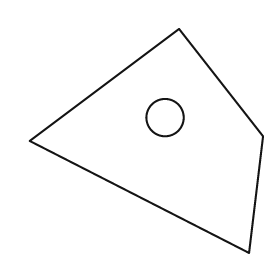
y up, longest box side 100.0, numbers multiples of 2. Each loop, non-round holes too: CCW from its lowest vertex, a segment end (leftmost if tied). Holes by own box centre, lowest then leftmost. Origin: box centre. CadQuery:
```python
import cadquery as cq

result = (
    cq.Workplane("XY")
    .moveTo(44.0, -48.0)
    .lineTo(50.0, 2.0)
    .lineTo(14.0, 48.0)
    .lineTo(-50.0, 0.0)
    .close()
    .moveTo(8.0, 10.0)
    .circle(8.0)
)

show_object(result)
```